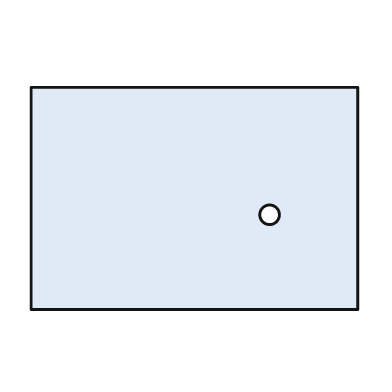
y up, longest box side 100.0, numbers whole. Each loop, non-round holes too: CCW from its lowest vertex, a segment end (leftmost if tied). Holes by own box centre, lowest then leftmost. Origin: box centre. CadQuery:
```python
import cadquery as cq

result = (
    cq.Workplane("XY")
    .moveTo(-50.0, -34.0)
    .lineTo(50.0, -34.0)
    .lineTo(50.0, 34.0)
    .lineTo(-50.0, 34.0)
    .close()
    .moveTo(23.0, -5.0)
    .circle(3.0)
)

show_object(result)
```